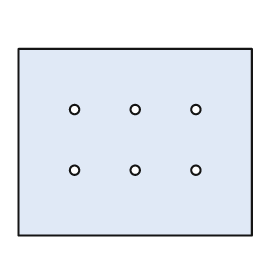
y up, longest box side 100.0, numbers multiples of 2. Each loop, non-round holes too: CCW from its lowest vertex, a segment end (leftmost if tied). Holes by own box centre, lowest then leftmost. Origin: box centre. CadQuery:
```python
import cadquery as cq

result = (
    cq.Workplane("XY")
    .moveTo(-50.0, -40.0)
    .lineTo(50.0, -40.0)
    .lineTo(50.0, 40.0)
    .lineTo(-50.0, 40.0)
    .close()
    .moveTo(-26.0, -12.0)
    .circle(2.0)
    .moveTo(0.0, -12.0)
    .circle(2.0)
    .moveTo(26.0, -12.0)
    .circle(2.0)
    .moveTo(-26.0, 14.0)
    .circle(2.0)
    .moveTo(0.0, 14.0)
    .circle(2.0)
    .moveTo(26.0, 14.0)
    .circle(2.0)
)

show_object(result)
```